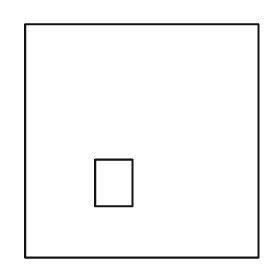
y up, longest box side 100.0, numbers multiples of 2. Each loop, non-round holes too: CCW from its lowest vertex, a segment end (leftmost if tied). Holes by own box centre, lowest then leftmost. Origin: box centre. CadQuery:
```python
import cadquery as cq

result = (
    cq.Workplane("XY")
    .moveTo(-50.0, -50.0)
    .lineTo(50.0, -50.0)
    .lineTo(50.0, 50.0)
    .lineTo(-50.0, 50.0)
    .close()
    .moveTo(-20.0, -28.0)
    .lineTo(-4.0, -28.0)
    .lineTo(-4.0, -8.0)
    .lineTo(-20.0, -8.0)
    .close()
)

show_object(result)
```